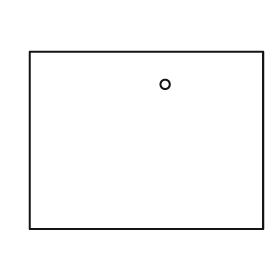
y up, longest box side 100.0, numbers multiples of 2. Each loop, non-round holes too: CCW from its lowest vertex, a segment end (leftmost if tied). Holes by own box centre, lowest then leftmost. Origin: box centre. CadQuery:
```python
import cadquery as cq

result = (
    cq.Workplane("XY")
    .moveTo(-50.0, -38.0)
    .lineTo(50.0, -38.0)
    .lineTo(50.0, 38.0)
    .lineTo(-50.0, 38.0)
    .close()
    .moveTo(8.0, 24.0)
    .circle(2.0)
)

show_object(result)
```